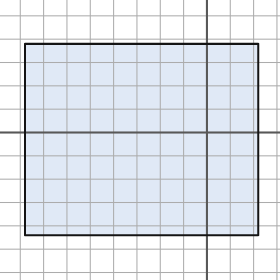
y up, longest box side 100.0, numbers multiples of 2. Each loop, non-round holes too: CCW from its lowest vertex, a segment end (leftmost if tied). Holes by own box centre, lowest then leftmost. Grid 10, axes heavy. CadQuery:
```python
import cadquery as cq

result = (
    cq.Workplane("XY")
    .moveTo(-78.0, -44.0)
    .lineTo(22.0, -44.0)
    .lineTo(22.0, 38.0)
    .lineTo(-78.0, 38.0)
    .close()
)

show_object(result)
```